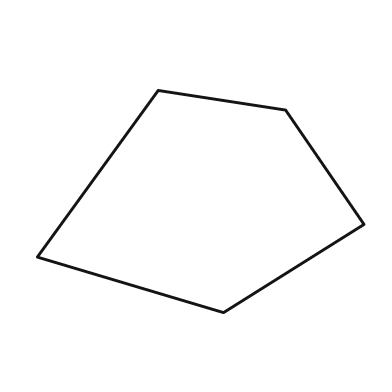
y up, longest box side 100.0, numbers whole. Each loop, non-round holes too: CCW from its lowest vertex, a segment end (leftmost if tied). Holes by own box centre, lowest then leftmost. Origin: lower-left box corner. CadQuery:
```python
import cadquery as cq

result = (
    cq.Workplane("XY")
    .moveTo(57.0, 0.0)
    .lineTo(100.0, 27.0)
    .lineTo(76.0, 62.0)
    .lineTo(37.0, 68.0)
    .lineTo(0.0, 17.0)
    .close()
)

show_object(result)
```